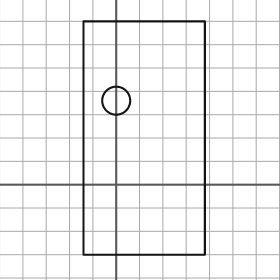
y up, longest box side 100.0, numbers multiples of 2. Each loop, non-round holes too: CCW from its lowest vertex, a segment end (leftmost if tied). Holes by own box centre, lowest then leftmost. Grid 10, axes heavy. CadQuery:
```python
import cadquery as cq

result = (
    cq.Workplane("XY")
    .moveTo(-14.0, -30.0)
    .lineTo(38.0, -30.0)
    .lineTo(38.0, 70.0)
    .lineTo(-14.0, 70.0)
    .close()
    .moveTo(0.0, 36.0)
    .circle(6.0)
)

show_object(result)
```